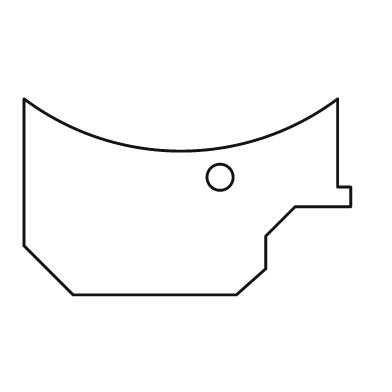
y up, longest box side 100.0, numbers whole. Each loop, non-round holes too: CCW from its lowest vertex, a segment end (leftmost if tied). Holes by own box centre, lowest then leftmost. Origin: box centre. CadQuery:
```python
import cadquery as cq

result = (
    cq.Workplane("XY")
    .moveTo(-35.0, -30.0)
    .lineTo(15.0, -30.0)
    .lineTo(24.0, -22.0)
    .lineTo(24.0, -12.0)
    .lineTo(33.0, -3.0)
    .lineTo(50.0, -3.0)
    .lineTo(50.0, 3.0)
    .lineTo(46.0, 3.0)
    .lineTo(46.0, 30.0)
    .threePointArc((-2.0, 14.0), (-50.0, 30.0))
    .lineTo(-50.0, -15.0)
    .close()
    .moveTo(10.0, 6.0)
    .circle(4.0)
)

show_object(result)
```